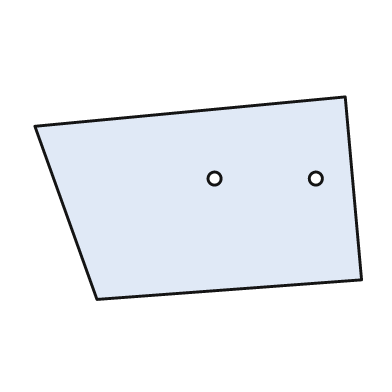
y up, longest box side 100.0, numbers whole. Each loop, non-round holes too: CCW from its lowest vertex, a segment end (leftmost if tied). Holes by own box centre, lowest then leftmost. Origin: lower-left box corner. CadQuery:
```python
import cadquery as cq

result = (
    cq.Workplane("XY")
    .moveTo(19.0, 0.0)
    .lineTo(100.0, 6.0)
    .lineTo(95.0, 62.0)
    .lineTo(0.0, 53.0)
    .close()
    .moveTo(55.0, 37.0)
    .circle(2.0)
    .moveTo(86.0, 37.0)
    .circle(2.0)
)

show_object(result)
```